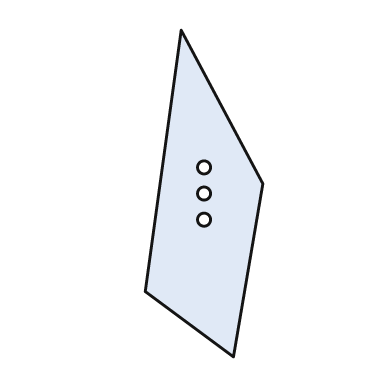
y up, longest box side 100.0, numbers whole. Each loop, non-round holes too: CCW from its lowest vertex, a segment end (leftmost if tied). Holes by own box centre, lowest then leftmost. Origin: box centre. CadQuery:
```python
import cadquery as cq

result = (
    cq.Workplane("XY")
    .moveTo(9.0, -50.0)
    .lineTo(18.0, 3.0)
    .lineTo(-7.0, 50.0)
    .lineTo(-18.0, -30.0)
    .close()
    .moveTo(0.0, -8.0)
    .circle(2.0)
    .moveTo(0.0, 0.0)
    .circle(2.0)
    .moveTo(0.0, 8.0)
    .circle(2.0)
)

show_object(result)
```